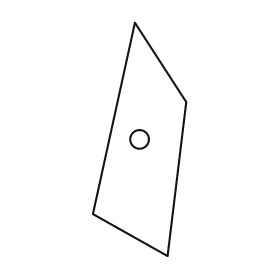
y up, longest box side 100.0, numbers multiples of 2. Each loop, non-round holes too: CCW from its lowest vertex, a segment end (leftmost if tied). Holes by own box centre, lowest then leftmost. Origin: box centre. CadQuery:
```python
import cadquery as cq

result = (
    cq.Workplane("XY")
    .moveTo(12.0, -50.0)
    .lineTo(20.0, 16.0)
    .lineTo(-2.0, 50.0)
    .lineTo(-20.0, -32.0)
    .close()
    .moveTo(0.0, 0.0)
    .circle(4.0)
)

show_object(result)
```